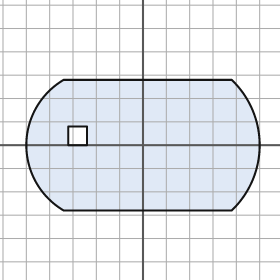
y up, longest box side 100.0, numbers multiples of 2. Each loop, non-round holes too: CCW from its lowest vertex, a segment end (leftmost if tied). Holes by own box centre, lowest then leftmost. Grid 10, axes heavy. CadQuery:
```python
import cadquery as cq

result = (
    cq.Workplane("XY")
    .moveTo(-34.0, -28.0)
    .lineTo(38.0, -28.0)
    .threePointArc((50.0, 0.0), (38.0, 28.0))
    .lineTo(-34.0, 28.0)
    .threePointArc((-50.0, 0.0), (-34.0, -28.0))
    .close()
    .moveTo(-32.0, 0.0)
    .lineTo(-24.0, 0.0)
    .lineTo(-24.0, 8.0)
    .lineTo(-32.0, 8.0)
    .close()
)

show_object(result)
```